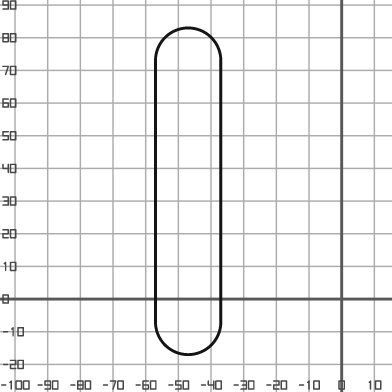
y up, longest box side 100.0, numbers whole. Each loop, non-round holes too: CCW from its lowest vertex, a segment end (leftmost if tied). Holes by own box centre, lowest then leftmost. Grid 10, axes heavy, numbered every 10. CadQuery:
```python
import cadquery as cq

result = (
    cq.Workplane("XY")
    .moveTo(-57.0, -7.0)
    .threePointArc((-47.0, -17.0), (-37.0, -7.0))
    .lineTo(-37.0, 73.0)
    .threePointArc((-47.0, 83.0), (-57.0, 73.0))
    .close()
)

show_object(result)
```